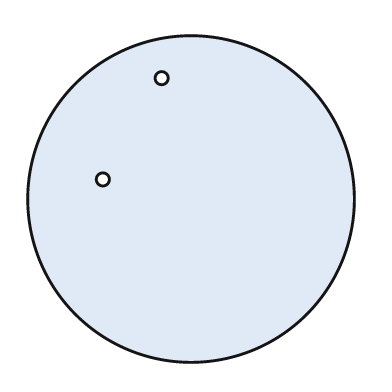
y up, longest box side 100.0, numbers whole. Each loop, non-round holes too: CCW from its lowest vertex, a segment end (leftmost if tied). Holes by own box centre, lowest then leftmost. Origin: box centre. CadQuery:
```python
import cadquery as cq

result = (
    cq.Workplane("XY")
    .moveTo(0.0, 0.0)
    .circle(50.0)
    .moveTo(-27.0, 6.0)
    .circle(2.0)
    .moveTo(-9.0, 37.0)
    .circle(2.0)
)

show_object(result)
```